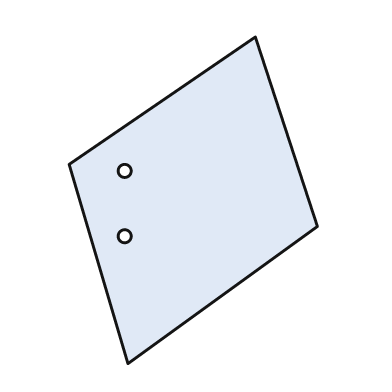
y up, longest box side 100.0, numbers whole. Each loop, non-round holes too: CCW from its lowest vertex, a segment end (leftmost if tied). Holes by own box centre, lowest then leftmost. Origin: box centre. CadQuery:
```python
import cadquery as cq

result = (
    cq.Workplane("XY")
    .moveTo(-20.0, -50.0)
    .lineTo(38.0, -8.0)
    .lineTo(19.0, 50.0)
    .lineTo(-38.0, 11.0)
    .close()
    .moveTo(-21.0, -11.0)
    .circle(2.0)
    .moveTo(-21.0, 9.0)
    .circle(2.0)
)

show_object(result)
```